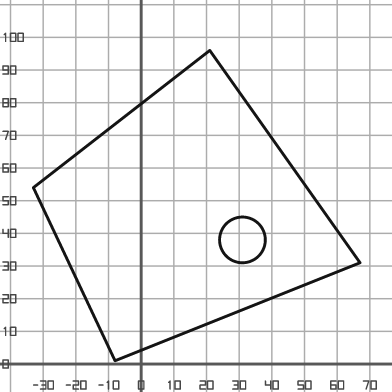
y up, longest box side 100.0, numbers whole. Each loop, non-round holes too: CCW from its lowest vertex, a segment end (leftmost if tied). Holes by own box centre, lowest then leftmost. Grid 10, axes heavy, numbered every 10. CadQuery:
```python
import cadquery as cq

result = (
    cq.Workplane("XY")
    .moveTo(-8.0, 1.0)
    .lineTo(67.0, 31.0)
    .lineTo(21.0, 96.0)
    .lineTo(-33.0, 54.0)
    .close()
    .moveTo(31.0, 38.0)
    .circle(7.0)
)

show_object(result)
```